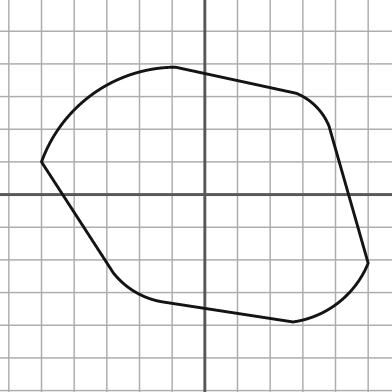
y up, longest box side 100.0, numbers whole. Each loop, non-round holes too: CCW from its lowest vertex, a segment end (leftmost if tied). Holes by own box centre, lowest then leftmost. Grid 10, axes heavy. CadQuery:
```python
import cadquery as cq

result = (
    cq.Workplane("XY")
    .moveTo(27.0, -39.0)
    .threePointArc((41.0, -33.0), (50.0, -21.0))
    .lineTo(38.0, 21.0)
    .threePointArc((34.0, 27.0), (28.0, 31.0))
    .lineTo(-9.0, 39.0)
    .threePointArc((-34.0, 31.0), (-50.0, 10.0))
    .lineTo(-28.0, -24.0)
    .threePointArc((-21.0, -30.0), (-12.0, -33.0))
    .close()
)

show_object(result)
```